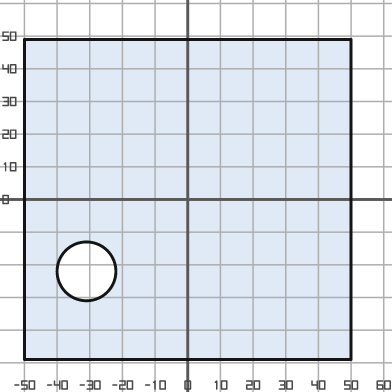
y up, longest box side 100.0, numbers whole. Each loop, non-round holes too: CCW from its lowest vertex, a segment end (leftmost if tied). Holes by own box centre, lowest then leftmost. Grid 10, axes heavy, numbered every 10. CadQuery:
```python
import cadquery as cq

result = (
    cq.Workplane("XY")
    .moveTo(-50.0, -49.0)
    .lineTo(50.0, -49.0)
    .lineTo(50.0, 49.0)
    .lineTo(-50.0, 49.0)
    .close()
    .moveTo(-31.0, -22.0)
    .circle(9.0)
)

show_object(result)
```